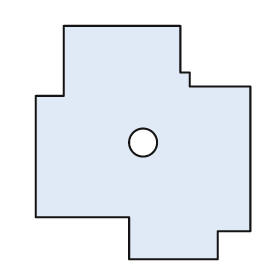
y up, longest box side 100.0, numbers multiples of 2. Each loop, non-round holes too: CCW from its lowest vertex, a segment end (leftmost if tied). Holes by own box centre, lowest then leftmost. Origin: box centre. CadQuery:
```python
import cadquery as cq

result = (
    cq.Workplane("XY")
    .moveTo(-6.0, -50.0)
    .lineTo(32.0, -50.0)
    .lineTo(32.0, -38.0)
    .lineTo(46.0, -38.0)
    .lineTo(46.0, 24.0)
    .lineTo(20.0, 24.0)
    .lineTo(20.0, 30.0)
    .lineTo(16.0, 30.0)
    .lineTo(16.0, 50.0)
    .lineTo(-34.0, 50.0)
    .lineTo(-34.0, 20.0)
    .lineTo(-46.0, 20.0)
    .lineTo(-46.0, -32.0)
    .lineTo(-6.0, -32.0)
    .close()
    .moveTo(0.0, 0.0)
    .circle(6.0)
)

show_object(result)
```